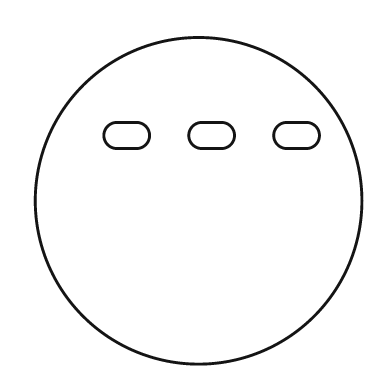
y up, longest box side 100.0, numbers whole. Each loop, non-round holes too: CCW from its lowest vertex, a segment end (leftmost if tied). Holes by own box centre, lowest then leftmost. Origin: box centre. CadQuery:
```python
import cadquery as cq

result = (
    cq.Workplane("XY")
    .moveTo(0.0, 0.0)
    .circle(50.0)
    .moveTo(-25.0, 16.0)
    .lineTo(-19.0, 16.0)
    .threePointArc((-15.0, 20.0), (-19.0, 24.0))
    .lineTo(-25.0, 24.0)
    .threePointArc((-29.0, 20.0), (-25.0, 16.0))
    .close()
    .moveTo(1.0, 16.0)
    .lineTo(7.0, 16.0)
    .threePointArc((11.0, 20.0), (7.0, 24.0))
    .lineTo(1.0, 24.0)
    .threePointArc((-3.0, 20.0), (1.0, 16.0))
    .close()
    .moveTo(27.0, 16.0)
    .lineTo(33.0, 16.0)
    .threePointArc((37.0, 20.0), (33.0, 24.0))
    .lineTo(27.0, 24.0)
    .threePointArc((23.0, 20.0), (27.0, 16.0))
    .close()
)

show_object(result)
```